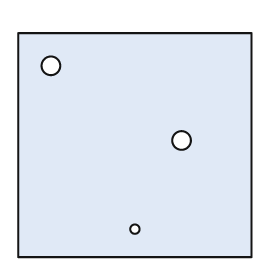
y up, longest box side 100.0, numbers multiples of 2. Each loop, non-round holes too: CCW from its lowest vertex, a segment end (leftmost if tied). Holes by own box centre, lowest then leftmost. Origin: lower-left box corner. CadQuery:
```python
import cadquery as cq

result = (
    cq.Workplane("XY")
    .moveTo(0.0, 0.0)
    .lineTo(100.0, 0.0)
    .lineTo(100.0, 96.0)
    .lineTo(0.0, 96.0)
    .close()
    .moveTo(50.0, 12.0)
    .circle(2.0)
    .moveTo(70.0, 50.0)
    .circle(4.0)
    .moveTo(14.0, 82.0)
    .circle(4.0)
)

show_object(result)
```